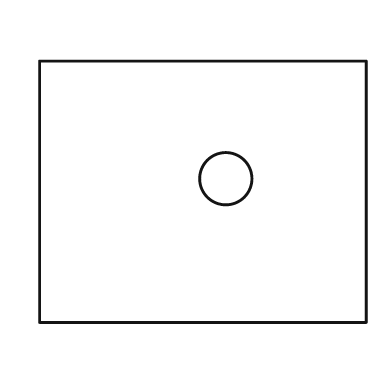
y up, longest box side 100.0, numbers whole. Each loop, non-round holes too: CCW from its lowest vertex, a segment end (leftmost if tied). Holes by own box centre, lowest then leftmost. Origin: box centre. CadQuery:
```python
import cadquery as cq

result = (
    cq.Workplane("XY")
    .moveTo(-50.0, -40.0)
    .lineTo(50.0, -40.0)
    .lineTo(50.0, 40.0)
    .lineTo(-50.0, 40.0)
    .close()
    .moveTo(7.0, 4.0)
    .circle(8.0)
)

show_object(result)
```